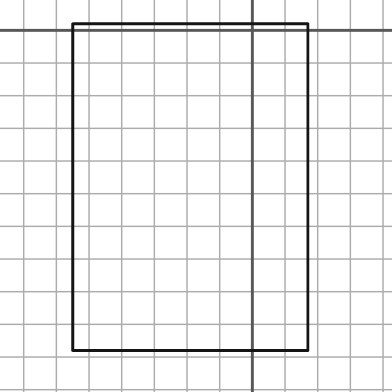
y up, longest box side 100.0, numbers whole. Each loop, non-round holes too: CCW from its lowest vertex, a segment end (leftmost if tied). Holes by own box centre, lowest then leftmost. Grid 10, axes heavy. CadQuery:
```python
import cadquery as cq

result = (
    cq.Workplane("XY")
    .moveTo(-55.0, -98.0)
    .lineTo(17.0, -98.0)
    .lineTo(17.0, 2.0)
    .lineTo(-55.0, 2.0)
    .close()
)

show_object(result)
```